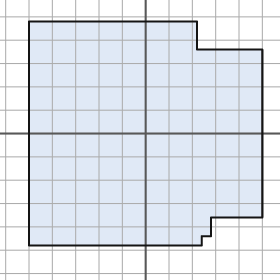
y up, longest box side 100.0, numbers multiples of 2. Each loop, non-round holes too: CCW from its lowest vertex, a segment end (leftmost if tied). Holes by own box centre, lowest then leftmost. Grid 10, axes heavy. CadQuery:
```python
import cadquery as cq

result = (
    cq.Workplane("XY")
    .moveTo(-50.0, -48.0)
    .lineTo(24.0, -48.0)
    .lineTo(24.0, -44.0)
    .lineTo(28.0, -44.0)
    .lineTo(28.0, -36.0)
    .lineTo(50.0, -36.0)
    .lineTo(50.0, 36.0)
    .lineTo(22.0, 36.0)
    .lineTo(22.0, 48.0)
    .lineTo(-50.0, 48.0)
    .close()
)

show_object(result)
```